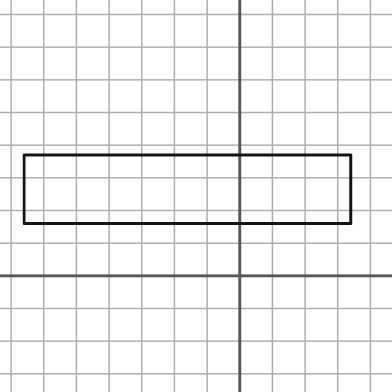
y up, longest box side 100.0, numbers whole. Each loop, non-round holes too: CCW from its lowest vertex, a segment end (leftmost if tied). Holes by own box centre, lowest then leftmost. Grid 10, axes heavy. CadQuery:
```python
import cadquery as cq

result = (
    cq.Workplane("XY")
    .moveTo(-66.0, 16.0)
    .lineTo(34.0, 16.0)
    .lineTo(34.0, 37.0)
    .lineTo(-66.0, 37.0)
    .close()
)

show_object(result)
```